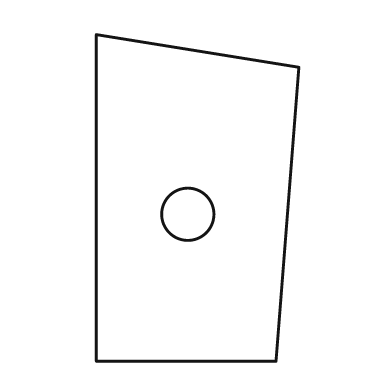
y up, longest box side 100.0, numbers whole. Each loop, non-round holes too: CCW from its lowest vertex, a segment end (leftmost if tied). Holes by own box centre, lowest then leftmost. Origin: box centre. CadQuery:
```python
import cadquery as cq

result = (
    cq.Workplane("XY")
    .moveTo(-31.0, -50.0)
    .lineTo(24.0, -50.0)
    .lineTo(31.0, 40.0)
    .lineTo(-31.0, 50.0)
    .close()
    .moveTo(-3.0, -5.0)
    .circle(8.0)
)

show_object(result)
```